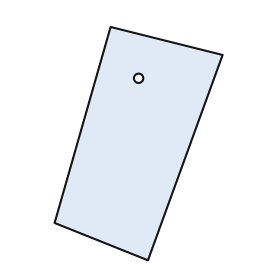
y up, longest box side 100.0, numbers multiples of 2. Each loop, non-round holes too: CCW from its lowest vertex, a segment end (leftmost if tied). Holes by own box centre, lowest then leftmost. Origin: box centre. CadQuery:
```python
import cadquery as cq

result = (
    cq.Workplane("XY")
    .moveTo(4.0, -50.0)
    .lineTo(36.0, 38.0)
    .lineTo(-12.0, 50.0)
    .lineTo(-36.0, -34.0)
    .close()
    .moveTo(0.0, 28.0)
    .circle(2.0)
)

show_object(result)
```